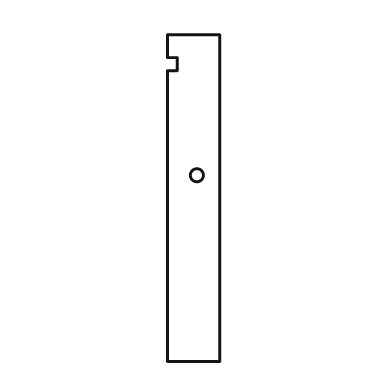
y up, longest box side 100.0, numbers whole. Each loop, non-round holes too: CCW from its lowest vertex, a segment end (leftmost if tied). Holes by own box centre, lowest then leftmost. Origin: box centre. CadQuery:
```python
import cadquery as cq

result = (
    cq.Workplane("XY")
    .moveTo(-8.0, -50.0)
    .lineTo(8.0, -50.0)
    .lineTo(8.0, 50.0)
    .lineTo(-8.0, 50.0)
    .lineTo(-8.0, 43.0)
    .lineTo(-5.0, 43.0)
    .lineTo(-5.0, 39.0)
    .lineTo(-8.0, 39.0)
    .close()
    .moveTo(1.0, 7.0)
    .circle(2.0)
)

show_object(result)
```